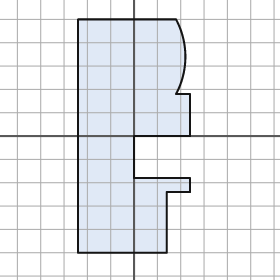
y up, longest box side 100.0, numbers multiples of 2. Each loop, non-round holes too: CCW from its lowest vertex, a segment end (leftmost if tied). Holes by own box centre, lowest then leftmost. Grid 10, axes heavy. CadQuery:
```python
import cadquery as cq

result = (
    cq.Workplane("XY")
    .moveTo(-24.0, -50.0)
    .lineTo(14.0, -50.0)
    .lineTo(14.0, -24.0)
    .lineTo(24.0, -24.0)
    .lineTo(24.0, -18.0)
    .lineTo(0.0, -18.0)
    .lineTo(0.0, 0.0)
    .lineTo(24.0, 0.0)
    .lineTo(24.0, 18.0)
    .lineTo(18.0, 18.0)
    .threePointArc((22.0, 34.0), (18.0, 50.0))
    .lineTo(-24.0, 50.0)
    .close()
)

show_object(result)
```